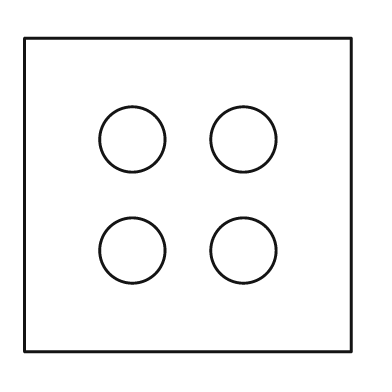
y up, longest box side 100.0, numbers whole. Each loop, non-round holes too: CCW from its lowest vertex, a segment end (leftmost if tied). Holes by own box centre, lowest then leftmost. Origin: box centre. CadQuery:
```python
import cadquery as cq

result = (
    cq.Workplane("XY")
    .moveTo(-50.0, -48.0)
    .lineTo(50.0, -48.0)
    .lineTo(50.0, 48.0)
    .lineTo(-50.0, 48.0)
    .close()
    .moveTo(-17.0, -17.0)
    .circle(10.0)
    .moveTo(17.0, -17.0)
    .circle(10.0)
    .moveTo(-17.0, 17.0)
    .circle(10.0)
    .moveTo(17.0, 17.0)
    .circle(10.0)
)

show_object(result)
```